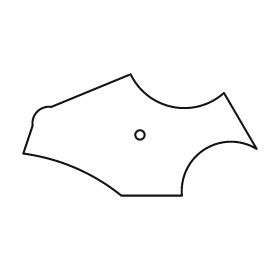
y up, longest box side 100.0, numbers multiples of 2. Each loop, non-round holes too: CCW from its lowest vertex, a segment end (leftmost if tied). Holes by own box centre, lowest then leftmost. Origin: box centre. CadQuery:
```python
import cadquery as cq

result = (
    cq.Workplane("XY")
    .moveTo(-8.0, -26.0)
    .lineTo(18.0, -26.0)
    .threePointArc((28.0, -6.0), (50.0, -6.0))
    .lineTo(36.0, 18.0)
    .threePointArc((14.0, 12.0), (-4.0, 26.0))
    .lineTo(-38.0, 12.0)
    .threePointArc((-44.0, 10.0), (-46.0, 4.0))
    .lineTo(-50.0, -8.0)
    .threePointArc((-28.0, -14.0), (-8.0, -26.0))
    .close()
    .moveTo(0.0, 0.0)
    .circle(2.0)
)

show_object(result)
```